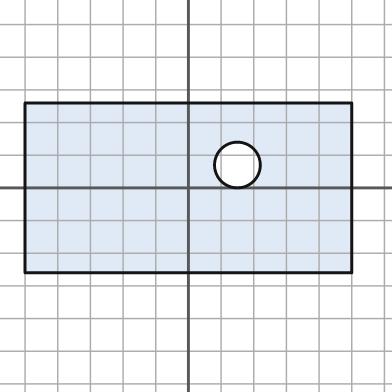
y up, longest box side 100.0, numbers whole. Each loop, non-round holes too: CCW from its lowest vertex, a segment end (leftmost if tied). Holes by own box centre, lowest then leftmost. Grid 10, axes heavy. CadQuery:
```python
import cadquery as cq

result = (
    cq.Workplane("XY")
    .moveTo(-50.0, -26.0)
    .lineTo(50.0, -26.0)
    .lineTo(50.0, 26.0)
    .lineTo(-50.0, 26.0)
    .close()
    .moveTo(15.0, 7.0)
    .circle(7.0)
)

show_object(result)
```